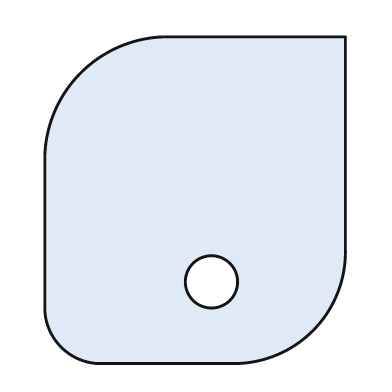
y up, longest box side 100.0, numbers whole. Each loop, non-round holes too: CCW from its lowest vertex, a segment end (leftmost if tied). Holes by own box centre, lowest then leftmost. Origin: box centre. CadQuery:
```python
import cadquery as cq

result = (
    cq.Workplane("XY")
    .moveTo(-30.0, -50.0)
    .lineTo(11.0, -50.0)
    .threePointArc((36.0, -40.0), (46.0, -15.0))
    .lineTo(46.0, 50.0)
    .lineTo(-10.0, 50.0)
    .threePointArc((-35.0, 39.0), (-46.0, 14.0))
    .lineTo(-46.0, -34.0)
    .threePointArc((-41.0, -45.0), (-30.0, -50.0))
    .close()
    .moveTo(5.0, -25.0)
    .circle(8.0)
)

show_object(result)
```